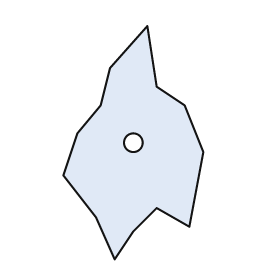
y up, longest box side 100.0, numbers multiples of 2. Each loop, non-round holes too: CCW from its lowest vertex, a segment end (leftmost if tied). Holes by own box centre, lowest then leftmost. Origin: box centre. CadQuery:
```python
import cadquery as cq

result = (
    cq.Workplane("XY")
    .moveTo(-8.0, -50.0)
    .lineTo(0.0, -38.0)
    .lineTo(10.0, -28.0)
    .lineTo(24.0, -36.0)
    .lineTo(30.0, -4.0)
    .lineTo(22.0, 16.0)
    .lineTo(10.0, 24.0)
    .lineTo(6.0, 50.0)
    .lineTo(-10.0, 32.0)
    .lineTo(-14.0, 16.0)
    .lineTo(-24.0, 4.0)
    .lineTo(-30.0, -14.0)
    .lineTo(-16.0, -32.0)
    .close()
    .moveTo(0.0, 0.0)
    .circle(4.0)
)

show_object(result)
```